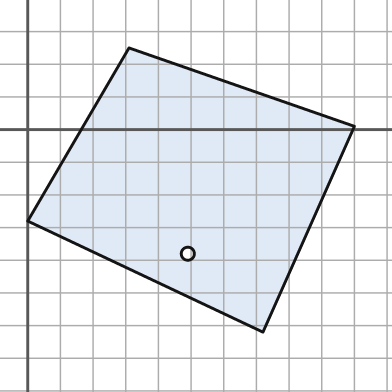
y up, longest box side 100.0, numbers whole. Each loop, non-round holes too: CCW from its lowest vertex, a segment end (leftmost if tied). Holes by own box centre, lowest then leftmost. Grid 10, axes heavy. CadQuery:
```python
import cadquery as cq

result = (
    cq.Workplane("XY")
    .moveTo(72.0, -62.0)
    .lineTo(100.0, 1.0)
    .lineTo(31.0, 25.0)
    .lineTo(0.0, -28.0)
    .close()
    .moveTo(49.0, -38.0)
    .circle(2.0)
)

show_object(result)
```